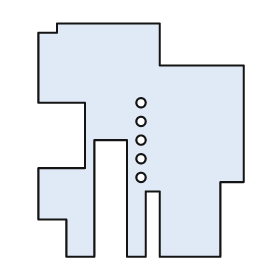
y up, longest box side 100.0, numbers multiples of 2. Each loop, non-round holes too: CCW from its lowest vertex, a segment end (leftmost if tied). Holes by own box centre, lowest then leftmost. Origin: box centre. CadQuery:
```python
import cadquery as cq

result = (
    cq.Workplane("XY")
    .moveTo(-32.0, -50.0)
    .lineTo(-20.0, -50.0)
    .lineTo(-20.0, 0.0)
    .lineTo(-6.0, 0.0)
    .lineTo(-6.0, -50.0)
    .lineTo(2.0, -50.0)
    .lineTo(2.0, -22.0)
    .lineTo(8.0, -22.0)
    .lineTo(8.0, -50.0)
    .lineTo(34.0, -50.0)
    .lineTo(34.0, -18.0)
    .lineTo(44.0, -18.0)
    .lineTo(44.0, 32.0)
    .lineTo(8.0, 32.0)
    .lineTo(8.0, 50.0)
    .lineTo(-36.0, 50.0)
    .lineTo(-36.0, 46.0)
    .lineTo(-44.0, 46.0)
    .lineTo(-44.0, 16.0)
    .lineTo(-24.0, 16.0)
    .lineTo(-24.0, -12.0)
    .lineTo(-44.0, -12.0)
    .lineTo(-44.0, -34.0)
    .lineTo(-32.0, -34.0)
    .close()
    .moveTo(0.0, -16.0)
    .circle(2.0)
    .moveTo(0.0, -8.0)
    .circle(2.0)
    .moveTo(0.0, 0.0)
    .circle(2.0)
    .moveTo(0.0, 8.0)
    .circle(2.0)
    .moveTo(0.0, 16.0)
    .circle(2.0)
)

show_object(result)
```